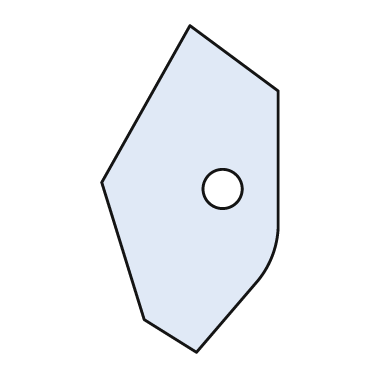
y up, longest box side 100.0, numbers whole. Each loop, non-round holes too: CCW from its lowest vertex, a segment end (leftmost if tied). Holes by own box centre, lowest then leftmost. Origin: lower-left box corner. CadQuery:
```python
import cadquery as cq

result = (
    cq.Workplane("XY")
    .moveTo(29.0, 0.0)
    .lineTo(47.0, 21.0)
    .threePointArc((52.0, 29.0), (54.0, 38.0))
    .lineTo(54.0, 80.0)
    .lineTo(27.0, 100.0)
    .lineTo(0.0, 52.0)
    .lineTo(13.0, 10.0)
    .close()
    .moveTo(37.0, 50.0)
    .circle(6.0)
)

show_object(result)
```